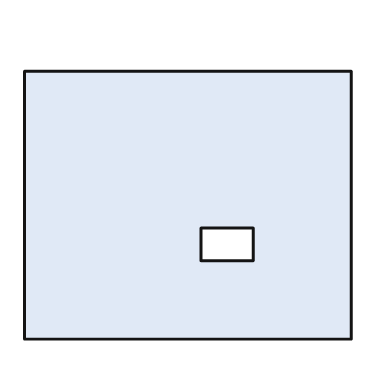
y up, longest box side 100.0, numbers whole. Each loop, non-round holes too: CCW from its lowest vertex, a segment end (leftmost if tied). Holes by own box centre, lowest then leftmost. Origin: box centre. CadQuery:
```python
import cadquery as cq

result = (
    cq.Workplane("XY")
    .moveTo(-50.0, -41.0)
    .lineTo(50.0, -41.0)
    .lineTo(50.0, 41.0)
    .lineTo(-50.0, 41.0)
    .close()
    .moveTo(4.0, -17.0)
    .lineTo(20.0, -17.0)
    .lineTo(20.0, -7.0)
    .lineTo(4.0, -7.0)
    .close()
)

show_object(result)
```